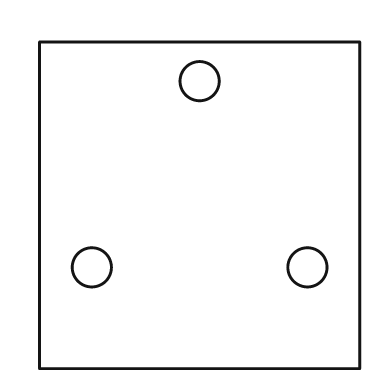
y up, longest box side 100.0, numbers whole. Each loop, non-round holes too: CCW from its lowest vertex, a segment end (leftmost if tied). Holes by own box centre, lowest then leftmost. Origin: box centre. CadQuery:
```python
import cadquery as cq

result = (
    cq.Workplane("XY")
    .moveTo(-49.0, -50.0)
    .lineTo(49.0, -50.0)
    .lineTo(49.0, 50.0)
    .lineTo(-49.0, 50.0)
    .close()
    .moveTo(-33.0, -19.0)
    .circle(6.0)
    .moveTo(33.0, -19.0)
    .circle(6.0)
    .moveTo(0.0, 38.0)
    .circle(6.0)
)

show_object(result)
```